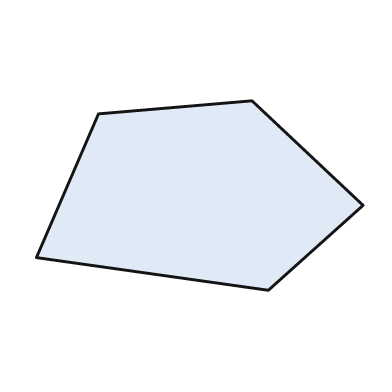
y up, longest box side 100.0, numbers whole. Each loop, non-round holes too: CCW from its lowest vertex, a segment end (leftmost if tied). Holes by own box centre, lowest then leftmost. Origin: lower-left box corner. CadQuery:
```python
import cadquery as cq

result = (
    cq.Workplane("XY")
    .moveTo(71.0, 0.0)
    .lineTo(100.0, 26.0)
    .lineTo(66.0, 58.0)
    .lineTo(19.0, 54.0)
    .lineTo(0.0, 10.0)
    .close()
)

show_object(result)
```